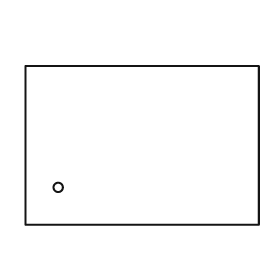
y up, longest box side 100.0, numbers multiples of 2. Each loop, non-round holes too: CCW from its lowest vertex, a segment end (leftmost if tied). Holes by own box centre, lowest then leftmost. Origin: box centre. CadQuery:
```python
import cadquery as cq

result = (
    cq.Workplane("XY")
    .moveTo(-50.0, -34.0)
    .lineTo(50.0, -34.0)
    .lineTo(50.0, 34.0)
    .lineTo(-50.0, 34.0)
    .close()
    .moveTo(-36.0, -18.0)
    .circle(2.0)
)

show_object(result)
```